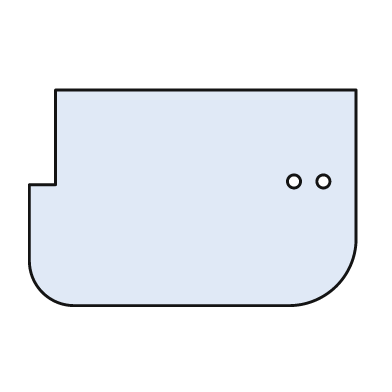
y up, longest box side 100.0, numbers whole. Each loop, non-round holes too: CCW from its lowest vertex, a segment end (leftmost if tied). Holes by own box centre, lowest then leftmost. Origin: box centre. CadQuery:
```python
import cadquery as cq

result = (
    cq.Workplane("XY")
    .moveTo(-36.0, -33.0)
    .lineTo(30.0, -33.0)
    .threePointArc((44.0, -27.0), (50.0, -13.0))
    .lineTo(50.0, 33.0)
    .lineTo(-42.0, 33.0)
    .lineTo(-42.0, 4.0)
    .lineTo(-50.0, 4.0)
    .lineTo(-50.0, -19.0)
    .threePointArc((-46.0, -29.0), (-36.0, -33.0))
    .close()
    .moveTo(31.0, 5.0)
    .circle(2.0)
    .moveTo(40.0, 5.0)
    .circle(2.0)
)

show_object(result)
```